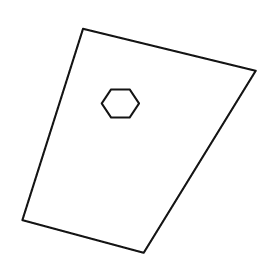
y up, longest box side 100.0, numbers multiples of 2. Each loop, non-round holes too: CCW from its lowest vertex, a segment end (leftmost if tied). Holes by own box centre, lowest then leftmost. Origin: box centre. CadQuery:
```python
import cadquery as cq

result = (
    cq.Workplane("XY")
    .moveTo(2.0, -48.0)
    .lineTo(50.0, 30.0)
    .lineTo(-24.0, 48.0)
    .lineTo(-50.0, -34.0)
    .close()
    .moveTo(-12.0, 10.0)
    .lineTo(-4.0, 10.0)
    .lineTo(0.0, 16.0)
    .lineTo(-4.0, 22.0)
    .lineTo(-12.0, 22.0)
    .lineTo(-16.0, 16.0)
    .close()
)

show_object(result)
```